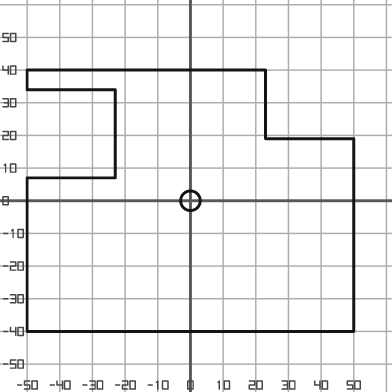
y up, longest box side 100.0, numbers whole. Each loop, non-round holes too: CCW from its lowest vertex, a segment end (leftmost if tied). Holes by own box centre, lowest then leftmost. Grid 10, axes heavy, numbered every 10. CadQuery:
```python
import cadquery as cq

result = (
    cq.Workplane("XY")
    .moveTo(-50.0, -40.0)
    .lineTo(50.0, -40.0)
    .lineTo(50.0, 19.0)
    .lineTo(23.0, 19.0)
    .lineTo(23.0, 40.0)
    .lineTo(-50.0, 40.0)
    .lineTo(-50.0, 34.0)
    .lineTo(-23.0, 34.0)
    .lineTo(-23.0, 7.0)
    .lineTo(-50.0, 7.0)
    .close()
    .moveTo(0.0, 0.0)
    .circle(3.0)
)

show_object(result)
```